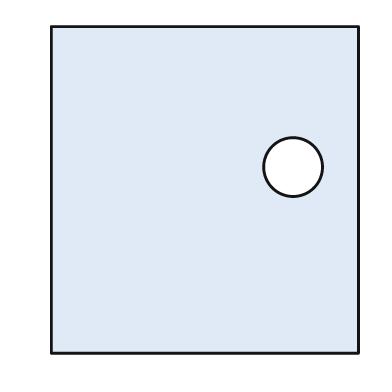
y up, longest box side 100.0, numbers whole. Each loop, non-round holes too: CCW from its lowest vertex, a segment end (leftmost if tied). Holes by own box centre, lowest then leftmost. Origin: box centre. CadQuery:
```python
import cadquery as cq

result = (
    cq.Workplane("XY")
    .moveTo(-47.0, -50.0)
    .lineTo(47.0, -50.0)
    .lineTo(47.0, 50.0)
    .lineTo(-47.0, 50.0)
    .close()
    .moveTo(27.0, 7.0)
    .circle(9.0)
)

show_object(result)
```